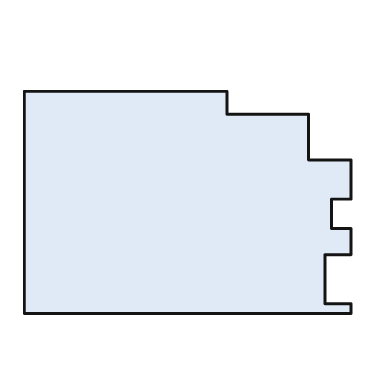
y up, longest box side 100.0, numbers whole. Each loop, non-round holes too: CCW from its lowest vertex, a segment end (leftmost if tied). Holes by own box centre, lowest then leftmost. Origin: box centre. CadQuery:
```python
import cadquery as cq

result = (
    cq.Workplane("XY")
    .moveTo(-50.0, -34.0)
    .lineTo(50.0, -34.0)
    .lineTo(50.0, -31.0)
    .lineTo(42.0, -31.0)
    .lineTo(42.0, -16.0)
    .lineTo(50.0, -16.0)
    .lineTo(50.0, -8.0)
    .lineTo(44.0, -8.0)
    .lineTo(44.0, 1.0)
    .lineTo(50.0, 1.0)
    .lineTo(50.0, 13.0)
    .lineTo(37.0, 13.0)
    .lineTo(37.0, 27.0)
    .lineTo(12.0, 27.0)
    .lineTo(12.0, 34.0)
    .lineTo(-50.0, 34.0)
    .close()
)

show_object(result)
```